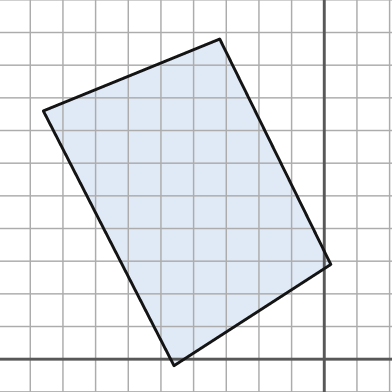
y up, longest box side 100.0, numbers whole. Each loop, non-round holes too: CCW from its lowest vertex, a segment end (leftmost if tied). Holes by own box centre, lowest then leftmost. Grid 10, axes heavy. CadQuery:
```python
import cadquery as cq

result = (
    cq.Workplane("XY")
    .moveTo(-46.0, -2.0)
    .lineTo(2.0, 29.0)
    .lineTo(-32.0, 98.0)
    .lineTo(-86.0, 76.0)
    .close()
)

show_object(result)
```